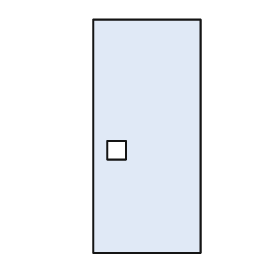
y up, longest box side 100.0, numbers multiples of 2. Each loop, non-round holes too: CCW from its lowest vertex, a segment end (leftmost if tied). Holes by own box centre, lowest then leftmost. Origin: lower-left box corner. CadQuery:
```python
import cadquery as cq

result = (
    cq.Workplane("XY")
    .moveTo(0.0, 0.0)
    .lineTo(46.0, 0.0)
    .lineTo(46.0, 100.0)
    .lineTo(0.0, 100.0)
    .close()
    .moveTo(6.0, 40.0)
    .lineTo(14.0, 40.0)
    .lineTo(14.0, 48.0)
    .lineTo(6.0, 48.0)
    .close()
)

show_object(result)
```